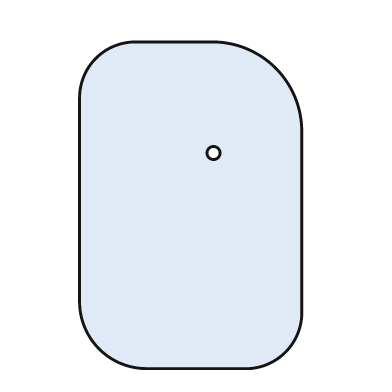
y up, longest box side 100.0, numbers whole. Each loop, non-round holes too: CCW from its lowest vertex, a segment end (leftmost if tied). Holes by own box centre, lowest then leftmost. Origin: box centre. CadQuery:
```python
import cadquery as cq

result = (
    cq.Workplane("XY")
    .moveTo(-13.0, -50.0)
    .lineTo(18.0, -50.0)
    .threePointArc((29.0, -45.0), (34.0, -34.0))
    .lineTo(34.0, 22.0)
    .threePointArc((26.0, 42.0), (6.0, 50.0))
    .lineTo(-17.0, 50.0)
    .threePointArc((-29.0, 45.0), (-34.0, 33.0))
    .lineTo(-34.0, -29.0)
    .threePointArc((-28.0, -44.0), (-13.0, -50.0))
    .close()
    .moveTo(7.0, 16.0)
    .circle(2.0)
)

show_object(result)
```